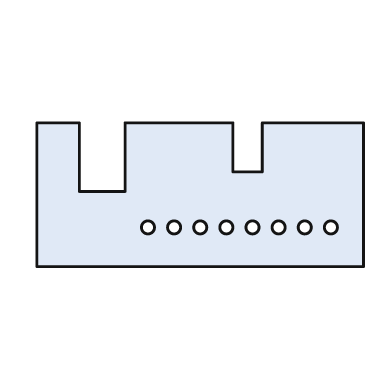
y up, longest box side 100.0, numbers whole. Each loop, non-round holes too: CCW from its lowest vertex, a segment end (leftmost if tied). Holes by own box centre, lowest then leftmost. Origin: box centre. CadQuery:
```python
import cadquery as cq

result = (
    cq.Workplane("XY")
    .moveTo(-50.0, -22.0)
    .lineTo(50.0, -22.0)
    .lineTo(50.0, 22.0)
    .lineTo(19.0, 22.0)
    .lineTo(19.0, 7.0)
    .lineTo(10.0, 7.0)
    .lineTo(10.0, 22.0)
    .lineTo(-23.0, 22.0)
    .lineTo(-23.0, 1.0)
    .lineTo(-37.0, 1.0)
    .lineTo(-37.0, 22.0)
    .lineTo(-50.0, 22.0)
    .close()
    .moveTo(-16.0, -10.0)
    .circle(2.0)
    .moveTo(-8.0, -10.0)
    .circle(2.0)
    .moveTo(0.0, -10.0)
    .circle(2.0)
    .moveTo(8.0, -10.0)
    .circle(2.0)
    .moveTo(16.0, -10.0)
    .circle(2.0)
    .moveTo(24.0, -10.0)
    .circle(2.0)
    .moveTo(32.0, -10.0)
    .circle(2.0)
    .moveTo(40.0, -10.0)
    .circle(2.0)
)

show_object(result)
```